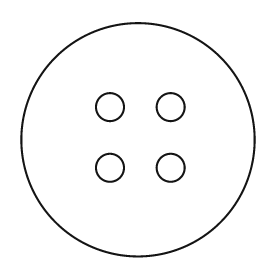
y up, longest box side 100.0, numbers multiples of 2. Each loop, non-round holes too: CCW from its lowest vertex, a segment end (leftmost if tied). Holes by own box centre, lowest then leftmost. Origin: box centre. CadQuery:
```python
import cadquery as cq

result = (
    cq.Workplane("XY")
    .moveTo(0.0, 0.0)
    .circle(50.0)
    .moveTo(-12.0, -12.0)
    .circle(6.0)
    .moveTo(14.0, -12.0)
    .circle(6.0)
    .moveTo(-12.0, 14.0)
    .circle(6.0)
    .moveTo(14.0, 14.0)
    .circle(6.0)
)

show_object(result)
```